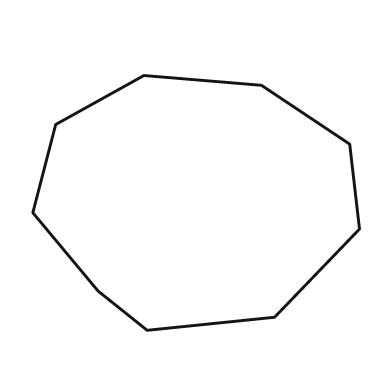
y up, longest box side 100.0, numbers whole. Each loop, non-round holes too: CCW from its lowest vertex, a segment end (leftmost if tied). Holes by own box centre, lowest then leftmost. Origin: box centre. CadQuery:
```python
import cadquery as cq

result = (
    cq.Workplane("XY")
    .moveTo(-15.0, -39.0)
    .lineTo(24.0, -35.0)
    .lineTo(50.0, -8.0)
    .lineTo(47.0, 18.0)
    .lineTo(20.0, 36.0)
    .lineTo(-16.0, 39.0)
    .lineTo(-43.0, 24.0)
    .lineTo(-50.0, -3.0)
    .lineTo(-30.0, -27.0)
    .close()
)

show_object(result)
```